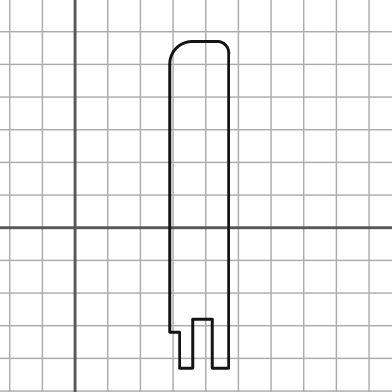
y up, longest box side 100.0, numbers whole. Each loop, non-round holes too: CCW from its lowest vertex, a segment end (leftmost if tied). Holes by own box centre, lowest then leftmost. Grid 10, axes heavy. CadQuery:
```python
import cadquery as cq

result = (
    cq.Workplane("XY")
    .moveTo(32.0, -43.0)
    .lineTo(36.0, -43.0)
    .lineTo(36.0, -28.0)
    .lineTo(42.0, -28.0)
    .lineTo(42.0, -43.0)
    .lineTo(47.0, -43.0)
    .lineTo(47.0, 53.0)
    .threePointArc((46.0, 56.0), (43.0, 57.0))
    .lineTo(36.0, 57.0)
    .threePointArc((31.0, 55.0), (29.0, 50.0))
    .lineTo(29.0, -32.0)
    .lineTo(32.0, -32.0)
    .close()
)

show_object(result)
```